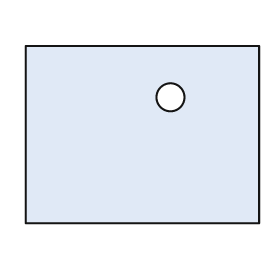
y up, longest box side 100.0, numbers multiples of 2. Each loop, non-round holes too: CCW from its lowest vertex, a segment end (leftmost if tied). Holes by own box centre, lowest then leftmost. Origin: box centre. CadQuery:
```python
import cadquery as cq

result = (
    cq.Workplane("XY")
    .moveTo(-50.0, -38.0)
    .lineTo(50.0, -38.0)
    .lineTo(50.0, 38.0)
    .lineTo(-50.0, 38.0)
    .close()
    .moveTo(12.0, 16.0)
    .circle(6.0)
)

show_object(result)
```